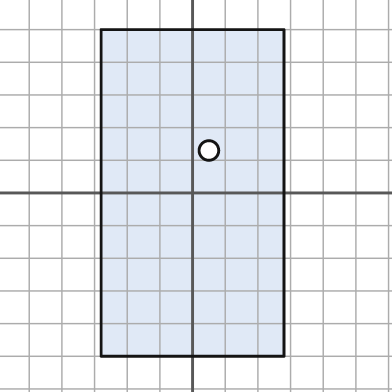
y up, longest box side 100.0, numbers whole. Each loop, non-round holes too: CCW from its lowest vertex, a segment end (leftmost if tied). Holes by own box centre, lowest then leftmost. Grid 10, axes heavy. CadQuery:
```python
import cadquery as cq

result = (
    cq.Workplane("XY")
    .moveTo(-28.0, -50.0)
    .lineTo(28.0, -50.0)
    .lineTo(28.0, 50.0)
    .lineTo(-28.0, 50.0)
    .close()
    .moveTo(5.0, 13.0)
    .circle(3.0)
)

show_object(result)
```